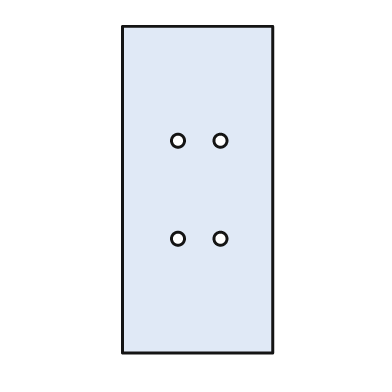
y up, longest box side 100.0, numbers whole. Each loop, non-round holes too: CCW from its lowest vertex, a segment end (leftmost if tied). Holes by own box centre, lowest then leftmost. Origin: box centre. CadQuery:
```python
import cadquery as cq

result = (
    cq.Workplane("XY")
    .moveTo(-23.0, -50.0)
    .lineTo(23.0, -50.0)
    .lineTo(23.0, 50.0)
    .lineTo(-23.0, 50.0)
    .close()
    .moveTo(-6.0, -15.0)
    .circle(2.0)
    .moveTo(7.0, -15.0)
    .circle(2.0)
    .moveTo(-6.0, 15.0)
    .circle(2.0)
    .moveTo(7.0, 15.0)
    .circle(2.0)
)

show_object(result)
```